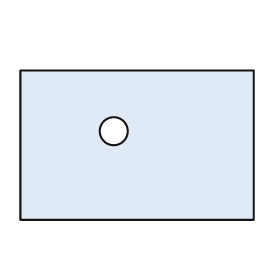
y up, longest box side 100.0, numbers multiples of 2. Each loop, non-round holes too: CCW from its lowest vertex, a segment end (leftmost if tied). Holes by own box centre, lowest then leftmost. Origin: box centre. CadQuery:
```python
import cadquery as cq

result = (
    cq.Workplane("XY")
    .moveTo(-50.0, -32.0)
    .lineTo(50.0, -32.0)
    .lineTo(50.0, 32.0)
    .lineTo(-50.0, 32.0)
    .close()
    .moveTo(-10.0, 6.0)
    .circle(6.0)
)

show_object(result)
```